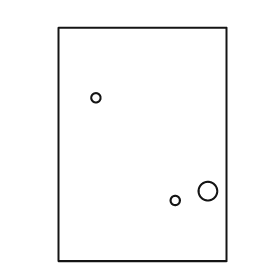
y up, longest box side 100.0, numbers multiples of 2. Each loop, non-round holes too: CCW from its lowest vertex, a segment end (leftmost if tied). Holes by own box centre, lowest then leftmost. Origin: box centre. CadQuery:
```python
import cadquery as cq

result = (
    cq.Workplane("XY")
    .moveTo(-36.0, -50.0)
    .lineTo(36.0, -50.0)
    .lineTo(36.0, 50.0)
    .lineTo(-36.0, 50.0)
    .close()
    .moveTo(14.0, -24.0)
    .circle(2.0)
    .moveTo(28.0, -20.0)
    .circle(4.0)
    .moveTo(-20.0, 20.0)
    .circle(2.0)
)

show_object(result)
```